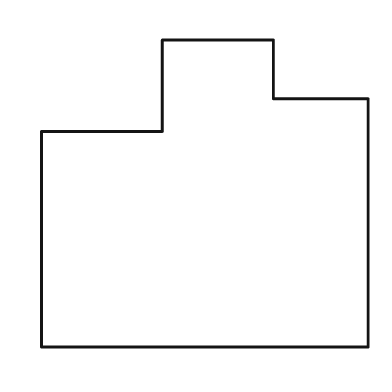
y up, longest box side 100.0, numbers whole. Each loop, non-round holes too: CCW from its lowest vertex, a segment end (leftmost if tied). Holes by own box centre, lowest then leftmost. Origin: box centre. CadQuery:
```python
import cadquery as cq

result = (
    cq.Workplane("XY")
    .moveTo(-50.0, -47.0)
    .lineTo(50.0, -47.0)
    .lineTo(50.0, 29.0)
    .lineTo(21.0, 29.0)
    .lineTo(21.0, 47.0)
    .lineTo(-13.0, 47.0)
    .lineTo(-13.0, 19.0)
    .lineTo(-50.0, 19.0)
    .close()
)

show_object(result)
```